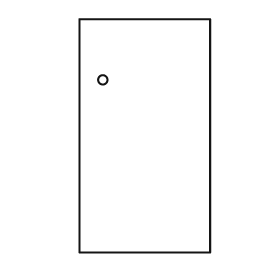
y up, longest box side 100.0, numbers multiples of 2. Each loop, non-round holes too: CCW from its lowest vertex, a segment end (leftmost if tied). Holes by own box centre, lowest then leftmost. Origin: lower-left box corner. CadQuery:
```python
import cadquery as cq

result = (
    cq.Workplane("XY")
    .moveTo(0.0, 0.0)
    .lineTo(56.0, 0.0)
    .lineTo(56.0, 100.0)
    .lineTo(0.0, 100.0)
    .close()
    .moveTo(10.0, 74.0)
    .circle(2.0)
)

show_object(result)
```